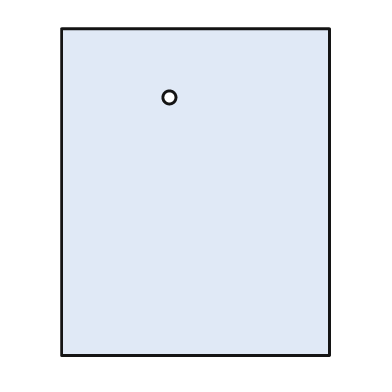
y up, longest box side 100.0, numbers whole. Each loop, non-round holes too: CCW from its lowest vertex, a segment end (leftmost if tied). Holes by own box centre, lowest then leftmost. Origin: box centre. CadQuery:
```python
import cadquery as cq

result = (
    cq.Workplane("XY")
    .moveTo(-41.0, -50.0)
    .lineTo(41.0, -50.0)
    .lineTo(41.0, 50.0)
    .lineTo(-41.0, 50.0)
    .close()
    .moveTo(-8.0, 29.0)
    .circle(2.0)
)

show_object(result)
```